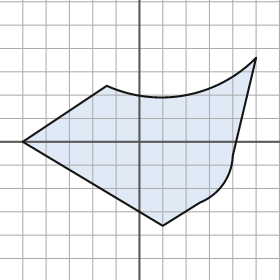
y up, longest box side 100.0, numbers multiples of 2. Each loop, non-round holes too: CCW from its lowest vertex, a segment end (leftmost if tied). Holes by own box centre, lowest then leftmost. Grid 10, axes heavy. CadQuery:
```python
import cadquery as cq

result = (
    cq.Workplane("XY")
    .moveTo(10.0, -36.0)
    .lineTo(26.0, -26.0)
    .threePointArc((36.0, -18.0), (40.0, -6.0))
    .lineTo(50.0, 36.0)
    .threePointArc((20.0, 20.0), (-14.0, 24.0))
    .lineTo(-50.0, 0.0)
    .close()
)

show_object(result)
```